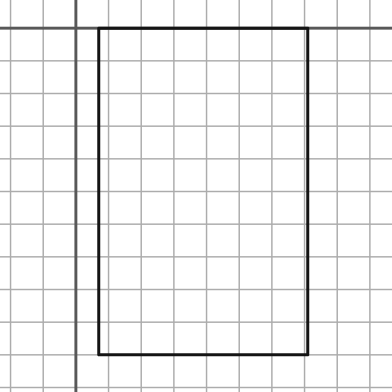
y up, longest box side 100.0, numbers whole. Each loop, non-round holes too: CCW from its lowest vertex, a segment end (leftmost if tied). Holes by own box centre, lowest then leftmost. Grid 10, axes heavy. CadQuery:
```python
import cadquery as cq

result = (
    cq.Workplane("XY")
    .moveTo(7.0, -100.0)
    .lineTo(71.0, -100.0)
    .lineTo(71.0, 0.0)
    .lineTo(7.0, 0.0)
    .close()
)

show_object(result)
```